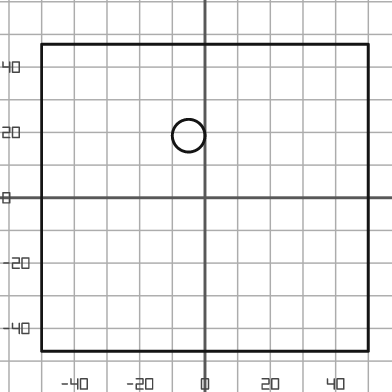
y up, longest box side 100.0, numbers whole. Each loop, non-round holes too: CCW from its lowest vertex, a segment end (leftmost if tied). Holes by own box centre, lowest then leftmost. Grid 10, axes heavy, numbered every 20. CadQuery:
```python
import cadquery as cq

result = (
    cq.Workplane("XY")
    .moveTo(-50.0, -47.0)
    .lineTo(50.0, -47.0)
    .lineTo(50.0, 47.0)
    .lineTo(-50.0, 47.0)
    .close()
    .moveTo(-5.0, 19.0)
    .circle(5.0)
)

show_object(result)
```